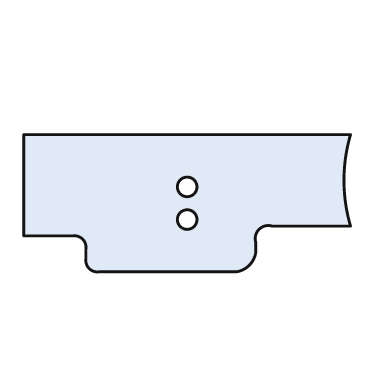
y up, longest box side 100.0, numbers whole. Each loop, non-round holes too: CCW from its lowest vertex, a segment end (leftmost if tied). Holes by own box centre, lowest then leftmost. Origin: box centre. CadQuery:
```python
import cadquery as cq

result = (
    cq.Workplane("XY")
    .moveTo(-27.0, -21.0)
    .lineTo(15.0, -21.0)
    .threePointArc((19.0, -19.0), (21.0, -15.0))
    .lineTo(21.0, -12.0)
    .threePointArc((22.0, -8.0), (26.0, -7.0))
    .lineTo(50.0, -7.0)
    .threePointArc((48.0, 7.0), (50.0, 21.0))
    .lineTo(-50.0, 21.0)
    .lineTo(-50.0, -10.0)
    .lineTo(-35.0, -10.0)
    .threePointArc((-32.0, -11.0), (-31.0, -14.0))
    .lineTo(-31.0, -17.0)
    .threePointArc((-30.0, -20.0), (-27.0, -21.0))
    .close()
    .moveTo(0.0, -5.0)
    .circle(3.0)
    .moveTo(0.0, 5.0)
    .circle(3.0)
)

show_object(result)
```